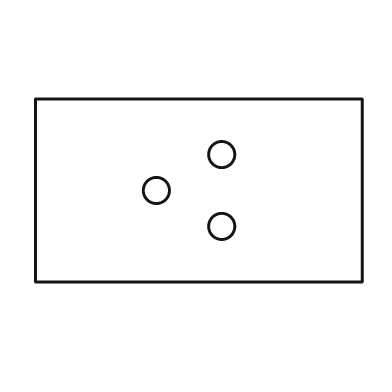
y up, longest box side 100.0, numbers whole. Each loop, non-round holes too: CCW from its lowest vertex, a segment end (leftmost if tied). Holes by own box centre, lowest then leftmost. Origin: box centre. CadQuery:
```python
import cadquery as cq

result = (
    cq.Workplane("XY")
    .moveTo(-50.0, -28.0)
    .lineTo(50.0, -28.0)
    .lineTo(50.0, 28.0)
    .lineTo(-50.0, 28.0)
    .close()
    .moveTo(7.0, -11.0)
    .circle(4.0)
    .moveTo(-13.0, 0.0)
    .circle(4.0)
    .moveTo(7.0, 11.0)
    .circle(4.0)
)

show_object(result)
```